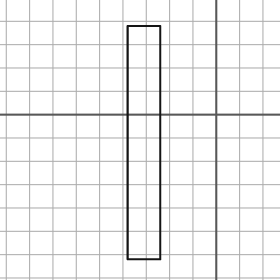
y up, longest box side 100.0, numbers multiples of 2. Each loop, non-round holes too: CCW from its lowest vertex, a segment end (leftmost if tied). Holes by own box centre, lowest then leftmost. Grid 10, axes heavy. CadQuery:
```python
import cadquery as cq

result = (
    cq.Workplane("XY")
    .moveTo(-38.0, -62.0)
    .lineTo(-24.0, -62.0)
    .lineTo(-24.0, 38.0)
    .lineTo(-38.0, 38.0)
    .close()
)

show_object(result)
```